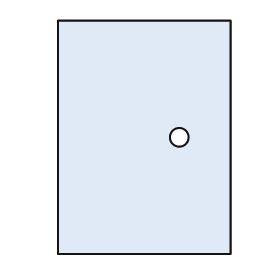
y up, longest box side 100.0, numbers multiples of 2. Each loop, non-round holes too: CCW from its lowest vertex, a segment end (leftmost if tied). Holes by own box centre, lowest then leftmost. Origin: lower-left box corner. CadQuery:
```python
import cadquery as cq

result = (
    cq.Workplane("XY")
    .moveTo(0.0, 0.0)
    .lineTo(74.0, 0.0)
    .lineTo(74.0, 100.0)
    .lineTo(0.0, 100.0)
    .close()
    .moveTo(52.0, 50.0)
    .circle(4.0)
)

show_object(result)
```